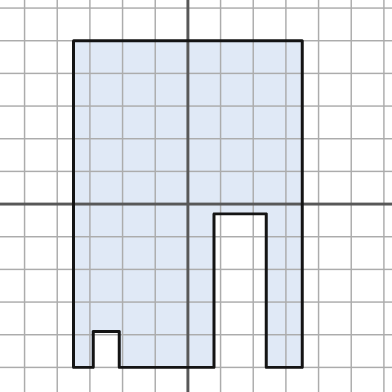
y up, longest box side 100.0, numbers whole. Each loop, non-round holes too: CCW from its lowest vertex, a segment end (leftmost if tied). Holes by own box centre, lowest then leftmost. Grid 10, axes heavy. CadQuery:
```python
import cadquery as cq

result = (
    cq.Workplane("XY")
    .moveTo(-35.0, -50.0)
    .lineTo(-29.0, -50.0)
    .lineTo(-29.0, -39.0)
    .lineTo(-21.0, -39.0)
    .lineTo(-21.0, -50.0)
    .lineTo(8.0, -50.0)
    .lineTo(8.0, -3.0)
    .lineTo(24.0, -3.0)
    .lineTo(24.0, -50.0)
    .lineTo(35.0, -50.0)
    .lineTo(35.0, 50.0)
    .lineTo(-35.0, 50.0)
    .close()
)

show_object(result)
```